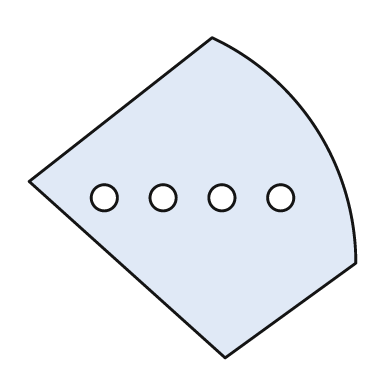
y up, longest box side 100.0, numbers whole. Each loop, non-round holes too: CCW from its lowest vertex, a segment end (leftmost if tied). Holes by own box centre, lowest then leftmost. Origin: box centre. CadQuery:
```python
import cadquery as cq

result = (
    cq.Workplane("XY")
    .moveTo(10.0, -49.0)
    .lineTo(50.0, -20.0)
    .threePointArc((38.0, 21.0), (6.0, 49.0))
    .lineTo(-50.0, 5.0)
    .close()
    .moveTo(-27.0, 0.0)
    .circle(4.0)
    .moveTo(-9.0, 0.0)
    .circle(4.0)
    .moveTo(9.0, 0.0)
    .circle(4.0)
    .moveTo(27.0, 0.0)
    .circle(4.0)
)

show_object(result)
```